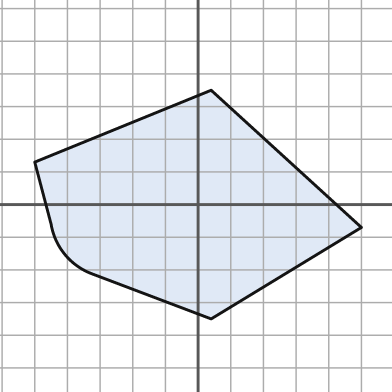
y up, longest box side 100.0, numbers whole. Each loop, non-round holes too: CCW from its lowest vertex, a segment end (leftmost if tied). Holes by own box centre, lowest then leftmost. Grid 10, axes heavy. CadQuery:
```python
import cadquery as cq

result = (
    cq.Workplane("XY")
    .moveTo(4.0, -35.0)
    .lineTo(50.0, -7.0)
    .lineTo(4.0, 35.0)
    .lineTo(-50.0, 13.0)
    .lineTo(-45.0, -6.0)
    .threePointArc((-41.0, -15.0), (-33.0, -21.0))
    .close()
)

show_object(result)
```